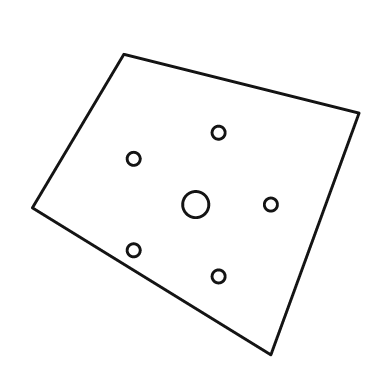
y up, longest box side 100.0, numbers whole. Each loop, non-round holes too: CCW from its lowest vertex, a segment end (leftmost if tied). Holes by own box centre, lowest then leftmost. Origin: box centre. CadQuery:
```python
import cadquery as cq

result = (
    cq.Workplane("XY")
    .moveTo(23.0, -46.0)
    .lineTo(50.0, 28.0)
    .lineTo(-22.0, 46.0)
    .lineTo(-50.0, -1.0)
    .close()
    .moveTo(7.0, -22.0)
    .circle(2.0)
    .moveTo(-19.0, -14.0)
    .circle(2.0)
    .moveTo(0.0, 0.0)
    .circle(4.0)
    .moveTo(23.0, 0.0)
    .circle(2.0)
    .moveTo(-19.0, 14.0)
    .circle(2.0)
    .moveTo(7.0, 22.0)
    .circle(2.0)
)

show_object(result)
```